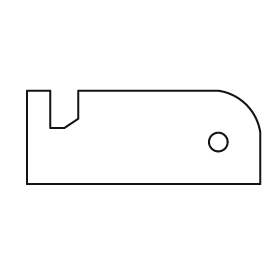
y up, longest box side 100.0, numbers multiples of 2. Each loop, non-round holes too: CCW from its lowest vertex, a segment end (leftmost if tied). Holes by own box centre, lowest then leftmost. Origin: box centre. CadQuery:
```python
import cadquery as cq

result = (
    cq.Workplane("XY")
    .moveTo(-50.0, -20.0)
    .lineTo(50.0, -20.0)
    .lineTo(50.0, 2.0)
    .threePointArc((44.0, 14.0), (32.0, 20.0))
    .lineTo(-28.0, 20.0)
    .lineTo(-28.0, 8.0)
    .lineTo(-34.0, 4.0)
    .lineTo(-40.0, 4.0)
    .lineTo(-40.0, 20.0)
    .lineTo(-50.0, 20.0)
    .close()
    .moveTo(32.0, -2.0)
    .circle(4.0)
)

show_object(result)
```